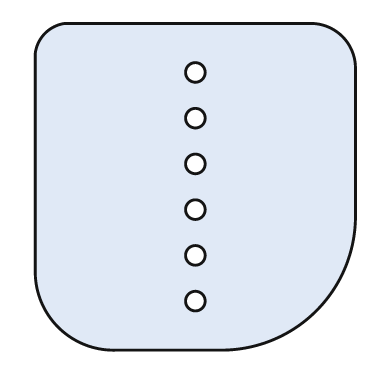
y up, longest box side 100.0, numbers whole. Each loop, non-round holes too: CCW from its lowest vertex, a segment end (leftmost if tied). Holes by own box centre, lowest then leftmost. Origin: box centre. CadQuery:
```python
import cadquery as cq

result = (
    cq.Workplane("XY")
    .moveTo(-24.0, -50.0)
    .lineTo(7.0, -50.0)
    .threePointArc((37.0, -38.0), (49.0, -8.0))
    .lineTo(49.0, 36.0)
    .threePointArc((45.0, 46.0), (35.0, 50.0))
    .lineTo(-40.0, 50.0)
    .threePointArc((-46.0, 47.0), (-49.0, 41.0))
    .lineTo(-49.0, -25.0)
    .threePointArc((-42.0, -43.0), (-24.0, -50.0))
    .close()
    .moveTo(0.0, -35.0)
    .circle(3.0)
    .moveTo(0.0, -21.0)
    .circle(3.0)
    .moveTo(0.0, -7.0)
    .circle(3.0)
    .moveTo(0.0, 7.0)
    .circle(3.0)
    .moveTo(0.0, 21.0)
    .circle(3.0)
    .moveTo(0.0, 35.0)
    .circle(3.0)
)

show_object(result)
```